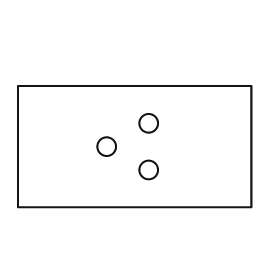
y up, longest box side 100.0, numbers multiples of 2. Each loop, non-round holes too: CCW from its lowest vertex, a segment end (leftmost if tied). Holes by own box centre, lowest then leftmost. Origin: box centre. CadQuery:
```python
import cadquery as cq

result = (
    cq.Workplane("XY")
    .moveTo(-50.0, -26.0)
    .lineTo(50.0, -26.0)
    .lineTo(50.0, 26.0)
    .lineTo(-50.0, 26.0)
    .close()
    .moveTo(6.0, -10.0)
    .circle(4.0)
    .moveTo(-12.0, 0.0)
    .circle(4.0)
    .moveTo(6.0, 10.0)
    .circle(4.0)
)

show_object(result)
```